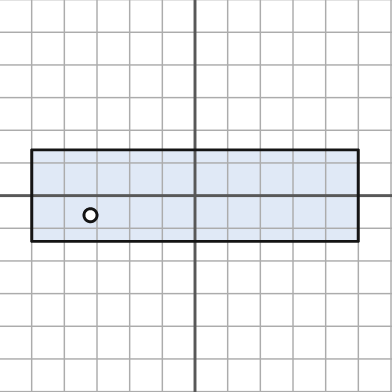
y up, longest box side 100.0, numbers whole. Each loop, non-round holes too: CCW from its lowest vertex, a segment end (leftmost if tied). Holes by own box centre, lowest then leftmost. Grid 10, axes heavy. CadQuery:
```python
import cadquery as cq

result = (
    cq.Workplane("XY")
    .moveTo(-50.0, -14.0)
    .lineTo(50.0, -14.0)
    .lineTo(50.0, 14.0)
    .lineTo(-50.0, 14.0)
    .close()
    .moveTo(-32.0, -6.0)
    .circle(2.0)
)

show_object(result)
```